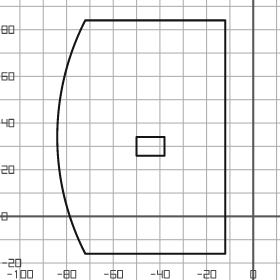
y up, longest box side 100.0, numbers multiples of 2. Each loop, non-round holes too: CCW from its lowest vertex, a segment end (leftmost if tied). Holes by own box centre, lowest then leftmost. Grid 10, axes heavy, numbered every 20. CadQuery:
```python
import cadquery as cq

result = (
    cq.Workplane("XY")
    .moveTo(-72.0, -16.0)
    .lineTo(-12.0, -16.0)
    .lineTo(-12.0, 84.0)
    .lineTo(-72.0, 84.0)
    .threePointArc((-84.0, 34.0), (-72.0, -16.0))
    .close()
    .moveTo(-50.0, 26.0)
    .lineTo(-38.0, 26.0)
    .lineTo(-38.0, 34.0)
    .lineTo(-50.0, 34.0)
    .close()
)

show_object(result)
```